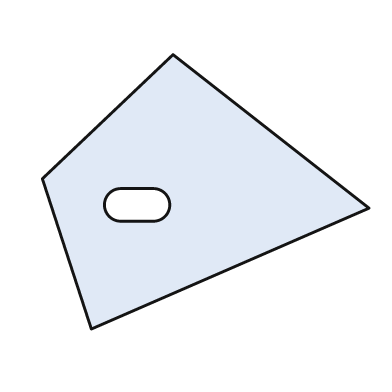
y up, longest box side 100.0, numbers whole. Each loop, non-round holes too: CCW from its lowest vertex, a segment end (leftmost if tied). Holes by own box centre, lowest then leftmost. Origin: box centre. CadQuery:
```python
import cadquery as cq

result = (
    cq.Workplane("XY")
    .moveTo(-35.0, -42.0)
    .lineTo(50.0, -5.0)
    .lineTo(-10.0, 42.0)
    .lineTo(-50.0, 4.0)
    .close()
    .moveTo(-26.0, -9.0)
    .lineTo(-16.0, -9.0)
    .threePointArc((-11.0, -4.0), (-16.0, 1.0))
    .lineTo(-26.0, 1.0)
    .threePointArc((-31.0, -4.0), (-26.0, -9.0))
    .close()
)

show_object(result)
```